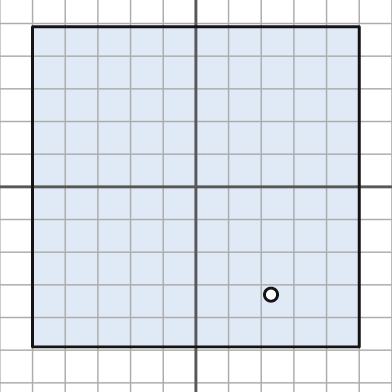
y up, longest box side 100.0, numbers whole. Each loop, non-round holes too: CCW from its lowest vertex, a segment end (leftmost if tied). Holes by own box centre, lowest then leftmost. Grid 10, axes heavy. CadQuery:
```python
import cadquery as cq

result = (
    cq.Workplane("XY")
    .moveTo(-50.0, -49.0)
    .lineTo(50.0, -49.0)
    .lineTo(50.0, 49.0)
    .lineTo(-50.0, 49.0)
    .close()
    .moveTo(23.0, -33.0)
    .circle(2.0)
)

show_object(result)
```